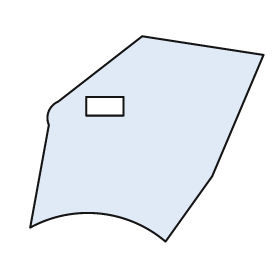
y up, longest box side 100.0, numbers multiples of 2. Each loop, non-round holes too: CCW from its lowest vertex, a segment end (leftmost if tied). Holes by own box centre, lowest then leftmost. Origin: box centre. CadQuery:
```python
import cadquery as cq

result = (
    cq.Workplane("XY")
    .moveTo(8.0, -44.0)
    .lineTo(28.0, -16.0)
    .lineTo(50.0, 36.0)
    .lineTo(-2.0, 44.0)
    .lineTo(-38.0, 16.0)
    .threePointArc((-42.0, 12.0), (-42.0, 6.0))
    .lineTo(-50.0, -38.0)
    .threePointArc((-20.0, -32.0), (8.0, -44.0))
    .close()
    .moveTo(-26.0, 10.0)
    .lineTo(-10.0, 10.0)
    .lineTo(-10.0, 18.0)
    .lineTo(-26.0, 18.0)
    .close()
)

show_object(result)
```